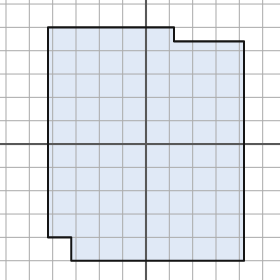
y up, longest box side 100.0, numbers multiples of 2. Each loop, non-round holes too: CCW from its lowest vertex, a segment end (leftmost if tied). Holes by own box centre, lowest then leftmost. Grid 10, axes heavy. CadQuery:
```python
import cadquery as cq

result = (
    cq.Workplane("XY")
    .moveTo(-32.0, -50.0)
    .lineTo(42.0, -50.0)
    .lineTo(42.0, 44.0)
    .lineTo(12.0, 44.0)
    .lineTo(12.0, 50.0)
    .lineTo(-42.0, 50.0)
    .lineTo(-42.0, -40.0)
    .lineTo(-32.0, -40.0)
    .close()
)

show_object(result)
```